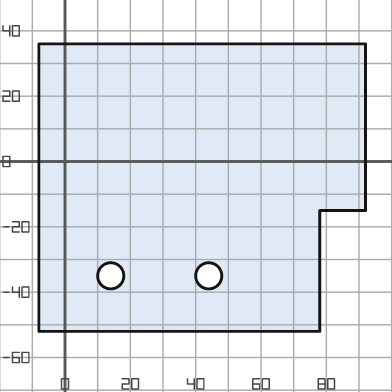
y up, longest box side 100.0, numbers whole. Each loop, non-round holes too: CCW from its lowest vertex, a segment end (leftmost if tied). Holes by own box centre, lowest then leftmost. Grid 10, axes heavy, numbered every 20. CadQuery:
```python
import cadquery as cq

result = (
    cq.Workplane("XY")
    .moveTo(-8.0, -52.0)
    .lineTo(78.0, -52.0)
    .lineTo(78.0, -15.0)
    .lineTo(92.0, -15.0)
    .lineTo(92.0, 36.0)
    .lineTo(-8.0, 36.0)
    .close()
    .moveTo(14.0, -35.0)
    .circle(4.0)
    .moveTo(44.0, -35.0)
    .circle(4.0)
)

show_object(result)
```